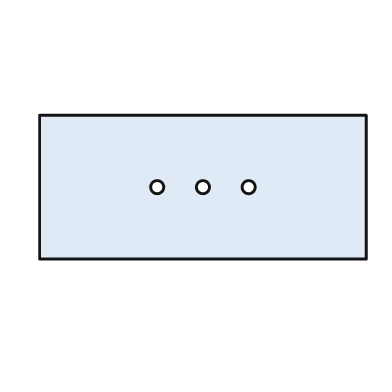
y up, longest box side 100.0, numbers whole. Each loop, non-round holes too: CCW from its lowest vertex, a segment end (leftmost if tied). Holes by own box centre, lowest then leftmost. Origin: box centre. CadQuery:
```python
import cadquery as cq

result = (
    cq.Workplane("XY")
    .moveTo(-50.0, -22.0)
    .lineTo(50.0, -22.0)
    .lineTo(50.0, 22.0)
    .lineTo(-50.0, 22.0)
    .close()
    .moveTo(-14.0, 0.0)
    .circle(2.0)
    .moveTo(0.0, 0.0)
    .circle(2.0)
    .moveTo(14.0, 0.0)
    .circle(2.0)
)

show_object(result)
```